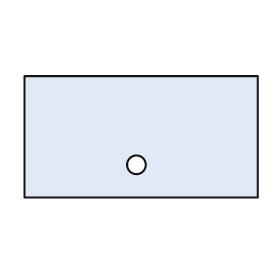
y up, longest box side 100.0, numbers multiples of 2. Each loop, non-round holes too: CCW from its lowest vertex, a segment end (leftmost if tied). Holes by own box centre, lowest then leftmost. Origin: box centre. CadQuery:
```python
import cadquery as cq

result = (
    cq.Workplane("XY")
    .moveTo(-50.0, -26.0)
    .lineTo(50.0, -26.0)
    .lineTo(50.0, 26.0)
    .lineTo(-50.0, 26.0)
    .close()
    .moveTo(-2.0, -12.0)
    .circle(4.0)
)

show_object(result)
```